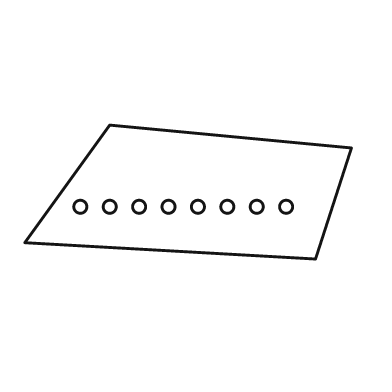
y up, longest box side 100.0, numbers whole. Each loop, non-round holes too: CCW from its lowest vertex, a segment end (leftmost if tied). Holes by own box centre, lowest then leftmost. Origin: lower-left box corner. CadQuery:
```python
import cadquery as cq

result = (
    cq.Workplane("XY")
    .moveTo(89.0, 0.0)
    .lineTo(100.0, 34.0)
    .lineTo(26.0, 41.0)
    .lineTo(0.0, 5.0)
    .close()
    .moveTo(17.0, 16.0)
    .circle(2.0)
    .moveTo(26.0, 16.0)
    .circle(2.0)
    .moveTo(35.0, 16.0)
    .circle(2.0)
    .moveTo(44.0, 16.0)
    .circle(2.0)
    .moveTo(53.0, 16.0)
    .circle(2.0)
    .moveTo(62.0, 16.0)
    .circle(2.0)
    .moveTo(71.0, 16.0)
    .circle(2.0)
    .moveTo(80.0, 16.0)
    .circle(2.0)
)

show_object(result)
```